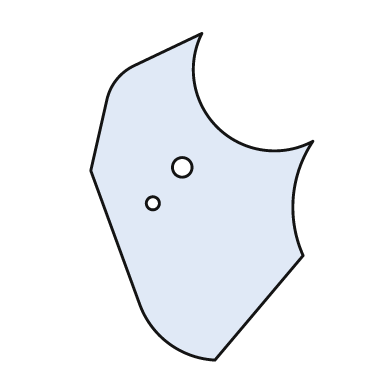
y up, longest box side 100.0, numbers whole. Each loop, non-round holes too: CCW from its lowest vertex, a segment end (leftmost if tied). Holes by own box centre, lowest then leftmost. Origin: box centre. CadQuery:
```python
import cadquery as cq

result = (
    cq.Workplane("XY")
    .moveTo(4.0, -50.0)
    .lineTo(31.0, -18.0)
    .threePointArc((28.0, 0.0), (34.0, 17.0))
    .threePointArc((5.0, 21.0), (0.0, 50.0))
    .lineTo(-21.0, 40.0)
    .threePointArc((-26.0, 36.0), (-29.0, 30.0))
    .lineTo(-34.0, 8.0)
    .lineTo(-19.0, -33.0)
    .threePointArc((-10.0, -45.0), (4.0, -50.0))
    .close()
    .moveTo(-15.0, -2.0)
    .circle(2.0)
    .moveTo(-6.0, 9.0)
    .circle(3.0)
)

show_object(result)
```